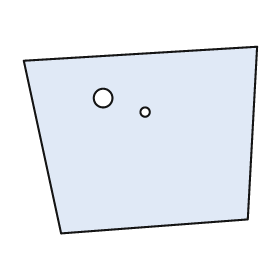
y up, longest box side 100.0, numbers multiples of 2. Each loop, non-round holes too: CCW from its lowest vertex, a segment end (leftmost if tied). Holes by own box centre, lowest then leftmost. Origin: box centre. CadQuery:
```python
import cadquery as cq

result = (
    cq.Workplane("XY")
    .moveTo(-34.0, -40.0)
    .lineTo(46.0, -34.0)
    .lineTo(50.0, 40.0)
    .lineTo(-50.0, 34.0)
    .close()
    .moveTo(2.0, 12.0)
    .circle(2.0)
    .moveTo(-16.0, 18.0)
    .circle(4.0)
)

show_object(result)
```